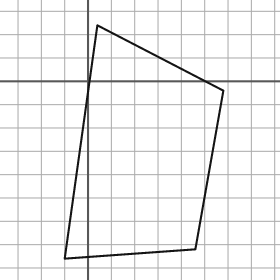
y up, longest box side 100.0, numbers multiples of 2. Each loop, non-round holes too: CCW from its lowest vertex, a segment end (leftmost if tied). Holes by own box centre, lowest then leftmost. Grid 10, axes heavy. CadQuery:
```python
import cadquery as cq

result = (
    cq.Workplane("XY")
    .moveTo(-10.0, -76.0)
    .lineTo(46.0, -72.0)
    .lineTo(58.0, -4.0)
    .lineTo(4.0, 24.0)
    .close()
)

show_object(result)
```